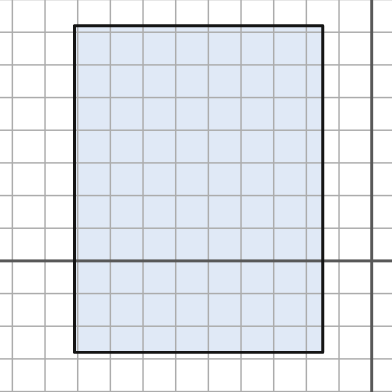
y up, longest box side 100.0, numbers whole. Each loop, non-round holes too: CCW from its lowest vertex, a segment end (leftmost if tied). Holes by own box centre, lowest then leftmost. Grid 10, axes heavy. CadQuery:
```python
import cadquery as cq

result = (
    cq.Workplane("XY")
    .moveTo(-91.0, -28.0)
    .lineTo(-15.0, -28.0)
    .lineTo(-15.0, 72.0)
    .lineTo(-91.0, 72.0)
    .close()
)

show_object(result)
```